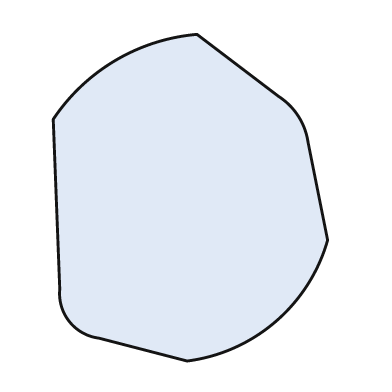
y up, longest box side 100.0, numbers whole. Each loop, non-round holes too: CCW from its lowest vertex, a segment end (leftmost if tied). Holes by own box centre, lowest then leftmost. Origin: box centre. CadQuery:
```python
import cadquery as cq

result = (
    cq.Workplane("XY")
    .moveTo(-1.0, -50.0)
    .threePointArc((26.0, -38.0), (42.0, -13.0))
    .lineTo(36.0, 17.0)
    .threePointArc((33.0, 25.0), (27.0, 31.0))
    .lineTo(2.0, 50.0)
    .threePointArc((-23.0, 42.0), (-42.0, 24.0))
    .lineTo(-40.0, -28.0)
    .threePointArc((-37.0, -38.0), (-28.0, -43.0))
    .close()
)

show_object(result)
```